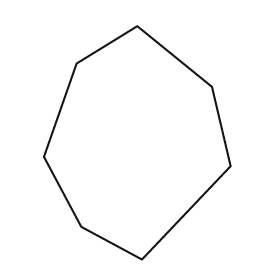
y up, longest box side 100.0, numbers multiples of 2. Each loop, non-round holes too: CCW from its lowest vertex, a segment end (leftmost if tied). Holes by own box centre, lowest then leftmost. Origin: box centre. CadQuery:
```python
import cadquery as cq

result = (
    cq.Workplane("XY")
    .moveTo(2.0, -50.0)
    .lineTo(40.0, -10.0)
    .lineTo(32.0, 24.0)
    .lineTo(0.0, 50.0)
    .lineTo(-26.0, 34.0)
    .lineTo(-40.0, -6.0)
    .lineTo(-24.0, -36.0)
    .close()
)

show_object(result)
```